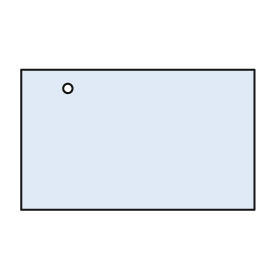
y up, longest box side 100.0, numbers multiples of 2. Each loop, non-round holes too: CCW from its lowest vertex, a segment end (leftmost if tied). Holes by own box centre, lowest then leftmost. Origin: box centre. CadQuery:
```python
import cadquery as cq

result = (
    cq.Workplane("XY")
    .moveTo(-50.0, -30.0)
    .lineTo(50.0, -30.0)
    .lineTo(50.0, 30.0)
    .lineTo(-50.0, 30.0)
    .close()
    .moveTo(-30.0, 22.0)
    .circle(2.0)
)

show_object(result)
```